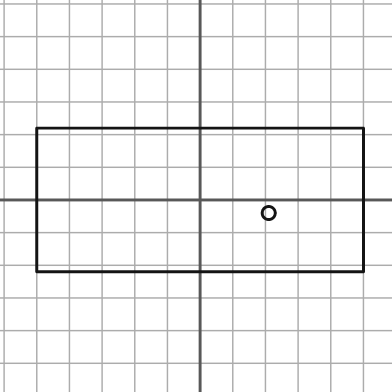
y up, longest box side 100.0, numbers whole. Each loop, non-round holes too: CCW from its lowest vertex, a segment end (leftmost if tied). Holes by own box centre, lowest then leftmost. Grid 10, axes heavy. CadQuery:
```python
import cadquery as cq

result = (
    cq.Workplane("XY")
    .moveTo(-50.0, -22.0)
    .lineTo(50.0, -22.0)
    .lineTo(50.0, 22.0)
    .lineTo(-50.0, 22.0)
    .close()
    .moveTo(21.0, -4.0)
    .circle(2.0)
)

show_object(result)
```